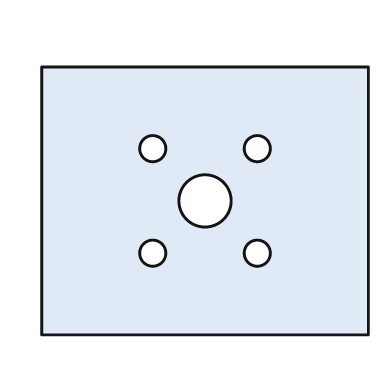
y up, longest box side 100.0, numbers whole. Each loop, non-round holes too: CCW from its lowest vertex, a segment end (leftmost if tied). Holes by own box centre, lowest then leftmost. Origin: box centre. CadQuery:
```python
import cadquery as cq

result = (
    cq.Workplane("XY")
    .moveTo(-50.0, -41.0)
    .lineTo(50.0, -41.0)
    .lineTo(50.0, 41.0)
    .lineTo(-50.0, 41.0)
    .close()
    .moveTo(-16.0, -16.0)
    .circle(4.0)
    .moveTo(16.0, -16.0)
    .circle(4.0)
    .moveTo(0.0, 0.0)
    .circle(8.0)
    .moveTo(-16.0, 16.0)
    .circle(4.0)
    .moveTo(16.0, 16.0)
    .circle(4.0)
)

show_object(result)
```